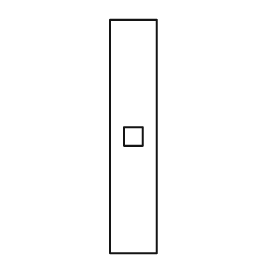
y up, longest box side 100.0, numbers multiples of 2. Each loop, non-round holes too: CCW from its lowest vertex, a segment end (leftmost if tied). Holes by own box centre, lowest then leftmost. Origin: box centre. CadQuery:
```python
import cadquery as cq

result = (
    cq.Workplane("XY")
    .moveTo(-10.0, -50.0)
    .lineTo(10.0, -50.0)
    .lineTo(10.0, 50.0)
    .lineTo(-10.0, 50.0)
    .close()
    .moveTo(-4.0, -4.0)
    .lineTo(4.0, -4.0)
    .lineTo(4.0, 4.0)
    .lineTo(-4.0, 4.0)
    .close()
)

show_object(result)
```